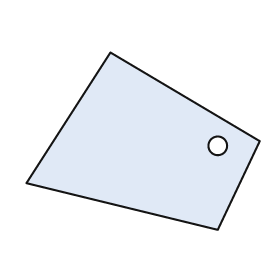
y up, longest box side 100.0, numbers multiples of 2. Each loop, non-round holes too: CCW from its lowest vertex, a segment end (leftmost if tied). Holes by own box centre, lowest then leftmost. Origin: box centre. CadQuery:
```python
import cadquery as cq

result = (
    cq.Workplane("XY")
    .moveTo(32.0, -38.0)
    .lineTo(50.0, 0.0)
    .lineTo(-14.0, 38.0)
    .lineTo(-50.0, -18.0)
    .close()
    .moveTo(32.0, -2.0)
    .circle(4.0)
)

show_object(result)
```